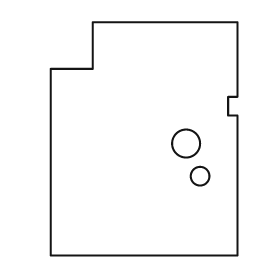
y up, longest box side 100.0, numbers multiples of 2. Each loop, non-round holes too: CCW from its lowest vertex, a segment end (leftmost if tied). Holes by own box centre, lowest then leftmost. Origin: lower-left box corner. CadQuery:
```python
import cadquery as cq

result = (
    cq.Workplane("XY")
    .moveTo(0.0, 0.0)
    .lineTo(80.0, 0.0)
    .lineTo(80.0, 60.0)
    .lineTo(76.0, 60.0)
    .lineTo(76.0, 68.0)
    .lineTo(80.0, 68.0)
    .lineTo(80.0, 100.0)
    .lineTo(18.0, 100.0)
    .lineTo(18.0, 80.0)
    .lineTo(0.0, 80.0)
    .close()
    .moveTo(64.0, 34.0)
    .circle(4.0)
    .moveTo(58.0, 48.0)
    .circle(6.0)
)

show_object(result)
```